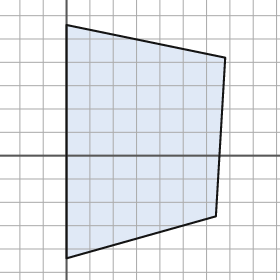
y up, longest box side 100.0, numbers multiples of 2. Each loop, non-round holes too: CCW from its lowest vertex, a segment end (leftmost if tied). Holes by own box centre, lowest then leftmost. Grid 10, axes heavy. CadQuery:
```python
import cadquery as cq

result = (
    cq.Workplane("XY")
    .moveTo(0.0, -44.0)
    .lineTo(64.0, -26.0)
    .lineTo(68.0, 42.0)
    .lineTo(0.0, 56.0)
    .close()
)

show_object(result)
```